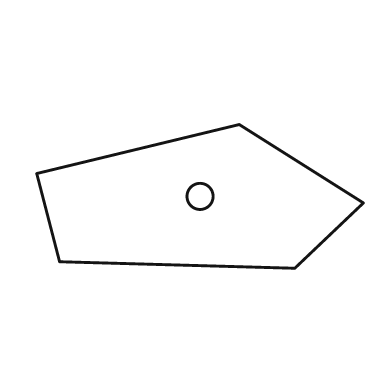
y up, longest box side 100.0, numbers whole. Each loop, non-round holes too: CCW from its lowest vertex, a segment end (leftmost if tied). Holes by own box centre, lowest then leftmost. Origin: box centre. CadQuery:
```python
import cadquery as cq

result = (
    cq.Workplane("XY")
    .moveTo(29.0, -22.0)
    .lineTo(50.0, -2.0)
    .lineTo(12.0, 22.0)
    .lineTo(-50.0, 7.0)
    .lineTo(-43.0, -20.0)
    .close()
    .moveTo(0.0, 0.0)
    .circle(4.0)
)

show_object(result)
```